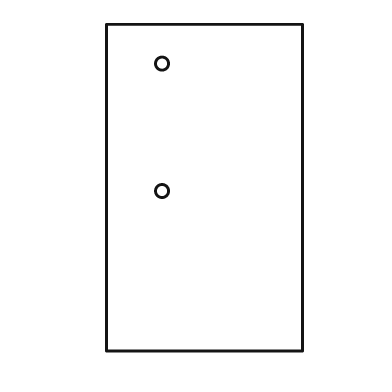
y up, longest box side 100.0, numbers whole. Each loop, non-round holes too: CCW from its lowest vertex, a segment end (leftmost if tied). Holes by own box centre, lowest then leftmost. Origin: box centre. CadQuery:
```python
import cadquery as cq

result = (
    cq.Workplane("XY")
    .moveTo(-30.0, -50.0)
    .lineTo(30.0, -50.0)
    .lineTo(30.0, 50.0)
    .lineTo(-30.0, 50.0)
    .close()
    .moveTo(-13.0, -1.0)
    .circle(2.0)
    .moveTo(-13.0, 38.0)
    .circle(2.0)
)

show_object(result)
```